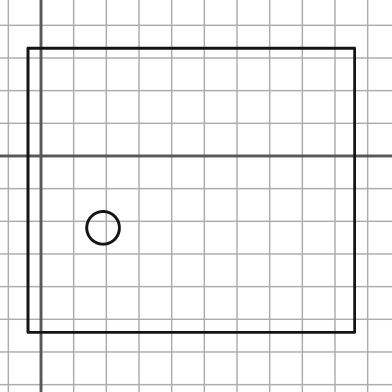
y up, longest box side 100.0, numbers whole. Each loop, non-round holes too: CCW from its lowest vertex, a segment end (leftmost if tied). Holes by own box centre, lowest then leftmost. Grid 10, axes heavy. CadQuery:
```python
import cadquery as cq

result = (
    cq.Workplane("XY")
    .moveTo(-4.0, -54.0)
    .lineTo(96.0, -54.0)
    .lineTo(96.0, 33.0)
    .lineTo(-4.0, 33.0)
    .close()
    .moveTo(19.0, -22.0)
    .circle(5.0)
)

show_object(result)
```